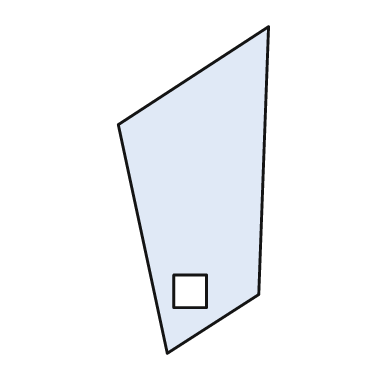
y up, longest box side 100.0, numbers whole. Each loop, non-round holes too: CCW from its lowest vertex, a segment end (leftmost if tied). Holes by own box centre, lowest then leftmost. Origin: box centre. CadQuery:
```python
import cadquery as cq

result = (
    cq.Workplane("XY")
    .moveTo(-8.0, -50.0)
    .lineTo(20.0, -32.0)
    .lineTo(23.0, 50.0)
    .lineTo(-23.0, 20.0)
    .close()
    .moveTo(-6.0, -36.0)
    .lineTo(4.0, -36.0)
    .lineTo(4.0, -26.0)
    .lineTo(-6.0, -26.0)
    .close()
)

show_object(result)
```